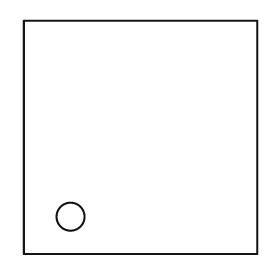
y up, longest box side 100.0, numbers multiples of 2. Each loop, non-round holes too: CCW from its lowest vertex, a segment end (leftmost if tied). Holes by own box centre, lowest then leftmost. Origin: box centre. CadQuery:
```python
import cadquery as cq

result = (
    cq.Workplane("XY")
    .moveTo(-50.0, -50.0)
    .lineTo(50.0, -50.0)
    .lineTo(50.0, 50.0)
    .lineTo(-50.0, 50.0)
    .close()
    .moveTo(-30.0, -34.0)
    .circle(6.0)
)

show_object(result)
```